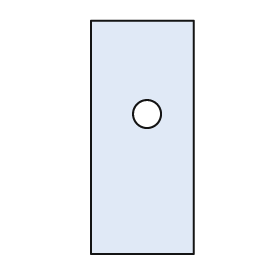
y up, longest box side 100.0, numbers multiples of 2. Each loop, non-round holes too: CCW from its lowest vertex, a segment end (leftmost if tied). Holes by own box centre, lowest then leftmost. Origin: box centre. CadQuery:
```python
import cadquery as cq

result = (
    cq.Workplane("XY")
    .moveTo(-22.0, -50.0)
    .lineTo(22.0, -50.0)
    .lineTo(22.0, 50.0)
    .lineTo(-22.0, 50.0)
    .close()
    .moveTo(2.0, 10.0)
    .circle(6.0)
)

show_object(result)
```